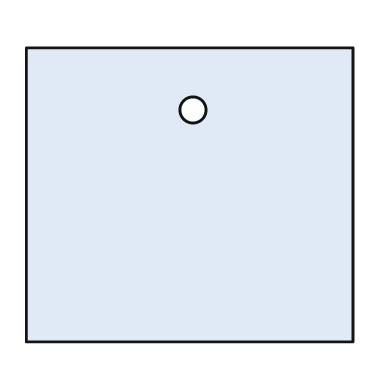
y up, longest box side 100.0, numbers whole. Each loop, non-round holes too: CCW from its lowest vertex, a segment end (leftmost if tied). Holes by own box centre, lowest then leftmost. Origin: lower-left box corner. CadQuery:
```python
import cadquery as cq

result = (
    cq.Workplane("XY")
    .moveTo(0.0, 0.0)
    .lineTo(100.0, 0.0)
    .lineTo(100.0, 90.0)
    .lineTo(0.0, 90.0)
    .close()
    .moveTo(51.0, 71.0)
    .circle(4.0)
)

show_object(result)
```